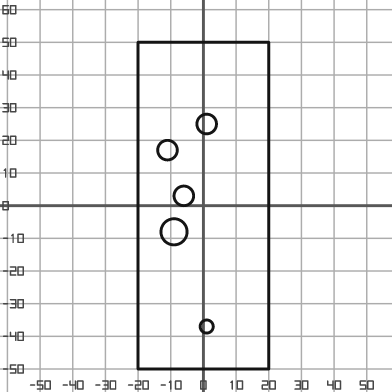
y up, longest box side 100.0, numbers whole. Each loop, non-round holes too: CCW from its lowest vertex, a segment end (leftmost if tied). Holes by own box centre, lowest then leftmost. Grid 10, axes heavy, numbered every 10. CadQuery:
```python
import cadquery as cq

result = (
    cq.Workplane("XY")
    .moveTo(-20.0, -50.0)
    .lineTo(20.0, -50.0)
    .lineTo(20.0, 50.0)
    .lineTo(-20.0, 50.0)
    .close()
    .moveTo(1.0, -37.0)
    .circle(2.0)
    .moveTo(-9.0, -8.0)
    .circle(4.0)
    .moveTo(-6.0, 3.0)
    .circle(3.0)
    .moveTo(-11.0, 17.0)
    .circle(3.0)
    .moveTo(1.0, 25.0)
    .circle(3.0)
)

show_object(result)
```